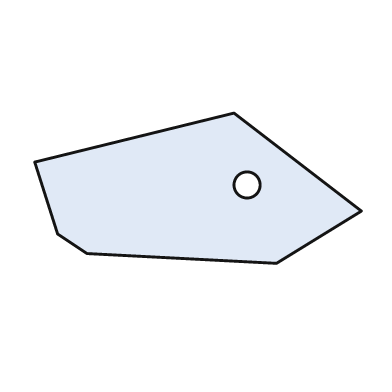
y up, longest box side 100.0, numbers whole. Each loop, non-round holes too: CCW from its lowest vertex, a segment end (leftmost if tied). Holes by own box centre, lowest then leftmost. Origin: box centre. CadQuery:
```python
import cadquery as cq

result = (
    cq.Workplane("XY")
    .moveTo(24.0, -23.0)
    .lineTo(50.0, -7.0)
    .lineTo(11.0, 23.0)
    .lineTo(-50.0, 8.0)
    .lineTo(-43.0, -14.0)
    .lineTo(-34.0, -20.0)
    .close()
    .moveTo(15.0, 1.0)
    .circle(4.0)
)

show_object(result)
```